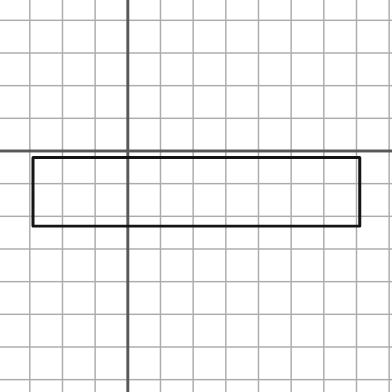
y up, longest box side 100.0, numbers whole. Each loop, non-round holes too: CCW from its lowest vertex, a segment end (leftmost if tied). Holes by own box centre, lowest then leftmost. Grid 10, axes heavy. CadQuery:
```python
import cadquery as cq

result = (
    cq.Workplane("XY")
    .moveTo(-29.0, -23.0)
    .lineTo(71.0, -23.0)
    .lineTo(71.0, -2.0)
    .lineTo(-29.0, -2.0)
    .close()
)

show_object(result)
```